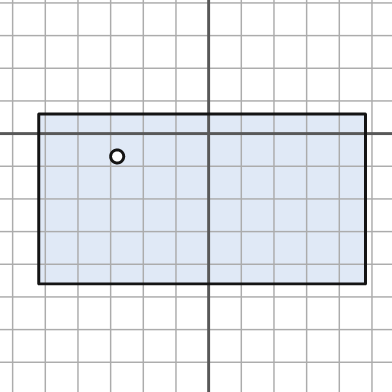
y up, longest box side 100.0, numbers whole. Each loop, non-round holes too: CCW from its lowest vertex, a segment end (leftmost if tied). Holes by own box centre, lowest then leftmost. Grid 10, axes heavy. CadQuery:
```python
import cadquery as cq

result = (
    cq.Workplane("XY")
    .moveTo(-52.0, -46.0)
    .lineTo(48.0, -46.0)
    .lineTo(48.0, 6.0)
    .lineTo(-52.0, 6.0)
    .close()
    .moveTo(-28.0, -7.0)
    .circle(2.0)
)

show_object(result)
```